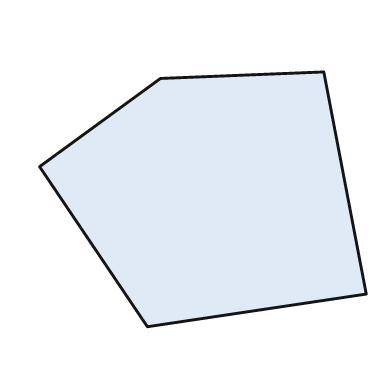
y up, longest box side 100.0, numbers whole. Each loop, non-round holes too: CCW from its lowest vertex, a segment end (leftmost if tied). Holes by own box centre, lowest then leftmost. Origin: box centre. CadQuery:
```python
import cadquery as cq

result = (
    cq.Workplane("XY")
    .moveTo(-17.0, -39.0)
    .lineTo(50.0, -29.0)
    .lineTo(37.0, 39.0)
    .lineTo(-13.0, 37.0)
    .lineTo(-50.0, 10.0)
    .close()
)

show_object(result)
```